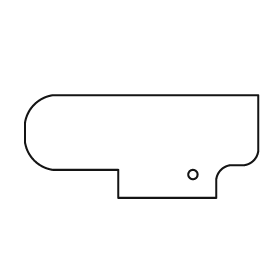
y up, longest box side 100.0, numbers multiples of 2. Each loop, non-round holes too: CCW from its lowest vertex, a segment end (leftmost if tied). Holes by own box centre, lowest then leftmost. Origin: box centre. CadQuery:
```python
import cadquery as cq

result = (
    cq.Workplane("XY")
    .moveTo(-10.0, -22.0)
    .lineTo(32.0, -22.0)
    .lineTo(32.0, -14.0)
    .threePointArc((34.0, -10.0), (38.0, -8.0))
    .lineTo(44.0, -8.0)
    .threePointArc((48.0, -6.0), (50.0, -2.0))
    .lineTo(50.0, 22.0)
    .lineTo(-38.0, 22.0)
    .threePointArc((-46.0, 18.0), (-50.0, 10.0))
    .lineTo(-50.0, 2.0)
    .threePointArc((-46.0, -6.0), (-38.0, -10.0))
    .lineTo(-10.0, -10.0)
    .close()
    .moveTo(22.0, -12.0)
    .circle(2.0)
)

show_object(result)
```